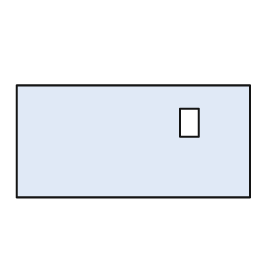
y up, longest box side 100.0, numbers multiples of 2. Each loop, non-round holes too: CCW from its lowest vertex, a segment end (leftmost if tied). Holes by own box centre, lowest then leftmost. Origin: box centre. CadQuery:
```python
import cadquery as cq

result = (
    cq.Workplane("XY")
    .moveTo(-50.0, -24.0)
    .lineTo(50.0, -24.0)
    .lineTo(50.0, 24.0)
    .lineTo(-50.0, 24.0)
    .close()
    .moveTo(20.0, 2.0)
    .lineTo(28.0, 2.0)
    .lineTo(28.0, 14.0)
    .lineTo(20.0, 14.0)
    .close()
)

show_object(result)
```